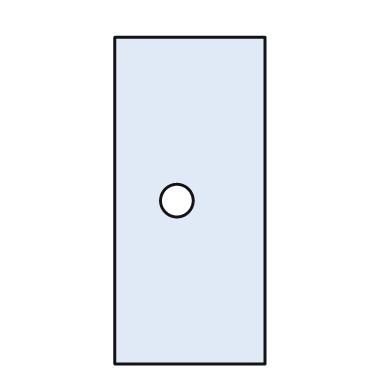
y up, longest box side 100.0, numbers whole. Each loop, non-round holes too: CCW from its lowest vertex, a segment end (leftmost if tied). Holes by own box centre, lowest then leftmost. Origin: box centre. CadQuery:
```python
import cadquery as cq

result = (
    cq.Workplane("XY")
    .moveTo(-23.0, -50.0)
    .lineTo(23.0, -50.0)
    .lineTo(23.0, 50.0)
    .lineTo(-23.0, 50.0)
    .close()
    .moveTo(-4.0, 0.0)
    .circle(5.0)
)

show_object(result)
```